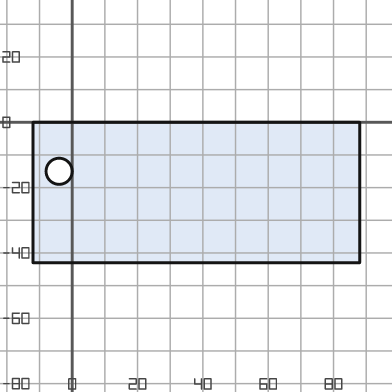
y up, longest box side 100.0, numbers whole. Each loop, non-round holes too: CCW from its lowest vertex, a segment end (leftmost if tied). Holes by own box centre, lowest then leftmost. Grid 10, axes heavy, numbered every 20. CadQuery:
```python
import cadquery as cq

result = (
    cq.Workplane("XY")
    .moveTo(-12.0, -43.0)
    .lineTo(88.0, -43.0)
    .lineTo(88.0, 0.0)
    .lineTo(-12.0, 0.0)
    .close()
    .moveTo(-4.0, -15.0)
    .circle(4.0)
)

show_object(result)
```